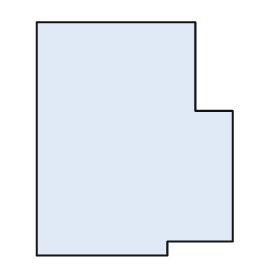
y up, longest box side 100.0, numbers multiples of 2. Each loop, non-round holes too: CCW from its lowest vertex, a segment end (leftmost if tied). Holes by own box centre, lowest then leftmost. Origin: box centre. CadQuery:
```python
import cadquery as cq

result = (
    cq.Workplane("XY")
    .moveTo(-42.0, -50.0)
    .lineTo(14.0, -50.0)
    .lineTo(14.0, -44.0)
    .lineTo(42.0, -44.0)
    .lineTo(42.0, 12.0)
    .lineTo(26.0, 12.0)
    .lineTo(26.0, 50.0)
    .lineTo(-42.0, 50.0)
    .close()
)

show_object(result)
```